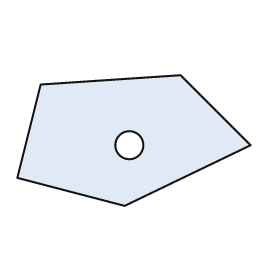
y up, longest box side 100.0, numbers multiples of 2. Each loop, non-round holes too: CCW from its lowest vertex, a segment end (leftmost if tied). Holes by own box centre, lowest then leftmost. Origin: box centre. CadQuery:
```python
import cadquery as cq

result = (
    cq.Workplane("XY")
    .moveTo(-4.0, -28.0)
    .lineTo(50.0, -2.0)
    .lineTo(20.0, 28.0)
    .lineTo(-40.0, 24.0)
    .lineTo(-50.0, -16.0)
    .close()
    .moveTo(-2.0, -2.0)
    .circle(6.0)
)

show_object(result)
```